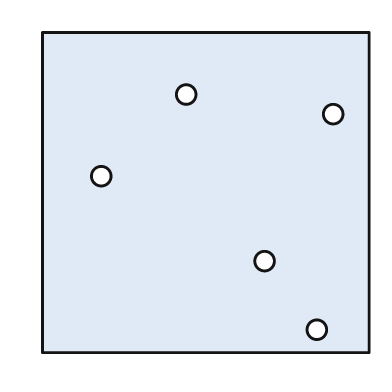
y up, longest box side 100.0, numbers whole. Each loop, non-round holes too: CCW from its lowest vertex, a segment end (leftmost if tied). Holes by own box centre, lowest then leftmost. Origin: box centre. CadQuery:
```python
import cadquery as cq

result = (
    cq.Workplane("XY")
    .moveTo(-50.0, -49.0)
    .lineTo(50.0, -49.0)
    .lineTo(50.0, 49.0)
    .lineTo(-50.0, 49.0)
    .close()
    .moveTo(34.0, -42.0)
    .circle(3.0)
    .moveTo(18.0, -21.0)
    .circle(3.0)
    .moveTo(-32.0, 5.0)
    .circle(3.0)
    .moveTo(39.0, 24.0)
    .circle(3.0)
    .moveTo(-6.0, 30.0)
    .circle(3.0)
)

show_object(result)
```